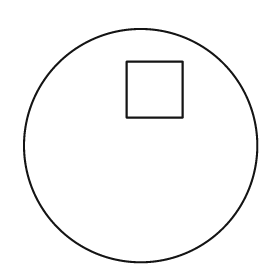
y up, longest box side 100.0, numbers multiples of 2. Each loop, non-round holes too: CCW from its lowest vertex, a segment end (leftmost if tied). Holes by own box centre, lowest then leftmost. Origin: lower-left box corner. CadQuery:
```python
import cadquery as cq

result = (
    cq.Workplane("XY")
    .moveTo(50.0, 50.0)
    .circle(50.0)
    .moveTo(44.0, 62.0)
    .lineTo(68.0, 62.0)
    .lineTo(68.0, 86.0)
    .lineTo(44.0, 86.0)
    .close()
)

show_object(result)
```